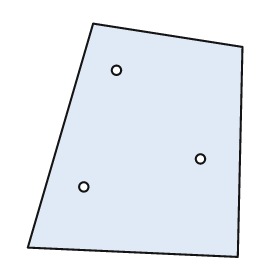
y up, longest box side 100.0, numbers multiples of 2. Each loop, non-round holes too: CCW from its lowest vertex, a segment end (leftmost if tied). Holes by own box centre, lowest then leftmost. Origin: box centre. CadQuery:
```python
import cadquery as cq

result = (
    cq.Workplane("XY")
    .moveTo(44.0, -50.0)
    .lineTo(46.0, 40.0)
    .lineTo(-18.0, 50.0)
    .lineTo(-46.0, -46.0)
    .close()
    .moveTo(-22.0, -20.0)
    .circle(2.0)
    .moveTo(28.0, -8.0)
    .circle(2.0)
    .moveTo(-8.0, 30.0)
    .circle(2.0)
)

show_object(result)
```